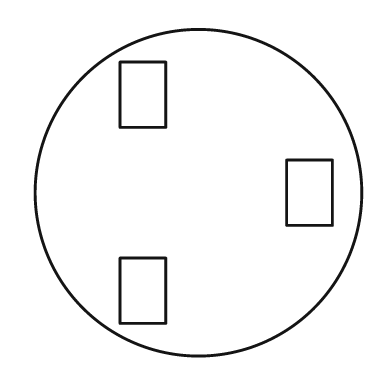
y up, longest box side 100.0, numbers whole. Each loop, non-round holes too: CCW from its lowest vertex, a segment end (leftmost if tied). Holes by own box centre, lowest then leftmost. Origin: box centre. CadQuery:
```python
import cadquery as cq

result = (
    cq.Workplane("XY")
    .moveTo(0.0, 0.0)
    .circle(50.0)
    .moveTo(-24.0, -40.0)
    .lineTo(-10.0, -40.0)
    .lineTo(-10.0, -20.0)
    .lineTo(-24.0, -20.0)
    .close()
    .moveTo(27.0, -10.0)
    .lineTo(41.0, -10.0)
    .lineTo(41.0, 10.0)
    .lineTo(27.0, 10.0)
    .close()
    .moveTo(-24.0, 20.0)
    .lineTo(-10.0, 20.0)
    .lineTo(-10.0, 40.0)
    .lineTo(-24.0, 40.0)
    .close()
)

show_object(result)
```